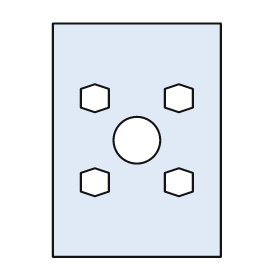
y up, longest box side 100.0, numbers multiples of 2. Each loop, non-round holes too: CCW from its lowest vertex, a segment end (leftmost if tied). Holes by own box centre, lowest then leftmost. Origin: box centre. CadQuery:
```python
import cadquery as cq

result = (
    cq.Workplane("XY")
    .moveTo(-36.0, -50.0)
    .lineTo(36.0, -50.0)
    .lineTo(36.0, 50.0)
    .lineTo(-36.0, 50.0)
    .close()
    .moveTo(-18.0, -24.0)
    .lineTo(-12.0, -22.0)
    .lineTo(-12.0, -14.0)
    .lineTo(-18.0, -12.0)
    .lineTo(-24.0, -14.0)
    .lineTo(-24.0, -22.0)
    .close()
    .moveTo(18.0, -24.0)
    .lineTo(24.0, -22.0)
    .lineTo(24.0, -14.0)
    .lineTo(18.0, -12.0)
    .lineTo(12.0, -14.0)
    .lineTo(12.0, -22.0)
    .close()
    .moveTo(0.0, 0.0)
    .circle(10.0)
    .moveTo(-18.0, 12.0)
    .lineTo(-12.0, 14.0)
    .lineTo(-12.0, 22.0)
    .lineTo(-18.0, 24.0)
    .lineTo(-24.0, 22.0)
    .lineTo(-24.0, 14.0)
    .close()
    .moveTo(18.0, 12.0)
    .lineTo(24.0, 14.0)
    .lineTo(24.0, 22.0)
    .lineTo(18.0, 24.0)
    .lineTo(12.0, 22.0)
    .lineTo(12.0, 14.0)
    .close()
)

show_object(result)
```